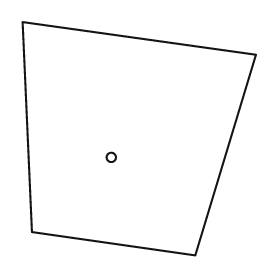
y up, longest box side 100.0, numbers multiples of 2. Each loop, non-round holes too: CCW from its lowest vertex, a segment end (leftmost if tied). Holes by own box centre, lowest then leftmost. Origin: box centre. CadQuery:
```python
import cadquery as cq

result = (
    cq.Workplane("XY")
    .moveTo(24.0, -50.0)
    .lineTo(50.0, 36.0)
    .lineTo(-50.0, 50.0)
    .lineTo(-46.0, -40.0)
    .close()
    .moveTo(-12.0, -8.0)
    .circle(2.0)
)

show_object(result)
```